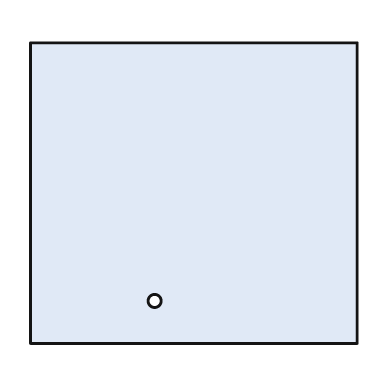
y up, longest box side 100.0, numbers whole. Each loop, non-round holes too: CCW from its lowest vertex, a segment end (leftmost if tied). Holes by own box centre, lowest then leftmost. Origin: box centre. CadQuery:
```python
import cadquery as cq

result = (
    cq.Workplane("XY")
    .moveTo(-50.0, -46.0)
    .lineTo(50.0, -46.0)
    .lineTo(50.0, 46.0)
    .lineTo(-50.0, 46.0)
    .close()
    .moveTo(-12.0, -33.0)
    .circle(2.0)
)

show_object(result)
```